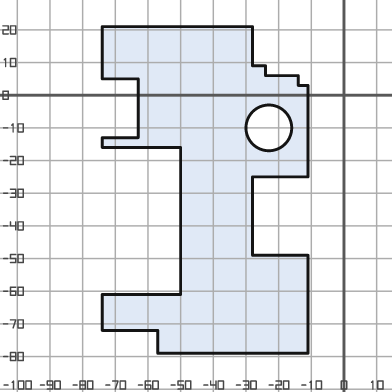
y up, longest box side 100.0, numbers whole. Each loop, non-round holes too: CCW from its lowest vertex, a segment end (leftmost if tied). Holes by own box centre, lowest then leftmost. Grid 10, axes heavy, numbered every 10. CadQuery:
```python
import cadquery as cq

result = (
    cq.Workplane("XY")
    .moveTo(-57.0, -79.0)
    .lineTo(-11.0, -79.0)
    .lineTo(-11.0, -49.0)
    .lineTo(-28.0, -49.0)
    .lineTo(-28.0, -25.0)
    .lineTo(-11.0, -25.0)
    .lineTo(-11.0, 3.0)
    .lineTo(-14.0, 3.0)
    .lineTo(-14.0, 6.0)
    .lineTo(-24.0, 6.0)
    .lineTo(-24.0, 9.0)
    .lineTo(-28.0, 9.0)
    .lineTo(-28.0, 21.0)
    .lineTo(-74.0, 21.0)
    .lineTo(-74.0, 5.0)
    .lineTo(-63.0, 5.0)
    .lineTo(-63.0, -13.0)
    .lineTo(-74.0, -13.0)
    .lineTo(-74.0, -16.0)
    .lineTo(-50.0, -16.0)
    .lineTo(-50.0, -61.0)
    .lineTo(-74.0, -61.0)
    .lineTo(-74.0, -72.0)
    .lineTo(-57.0, -72.0)
    .close()
    .moveTo(-23.0, -10.0)
    .circle(7.0)
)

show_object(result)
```